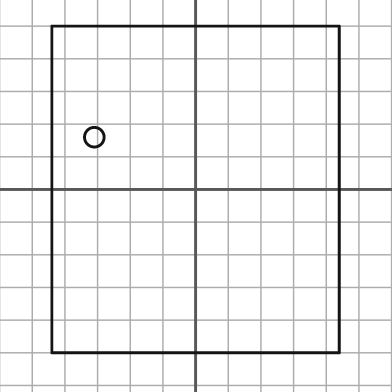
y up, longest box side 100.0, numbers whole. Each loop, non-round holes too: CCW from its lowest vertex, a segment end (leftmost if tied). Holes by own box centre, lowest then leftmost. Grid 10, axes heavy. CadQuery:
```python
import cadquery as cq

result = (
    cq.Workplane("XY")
    .moveTo(-44.0, -50.0)
    .lineTo(44.0, -50.0)
    .lineTo(44.0, 50.0)
    .lineTo(-44.0, 50.0)
    .close()
    .moveTo(-31.0, 16.0)
    .circle(3.0)
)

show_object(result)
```